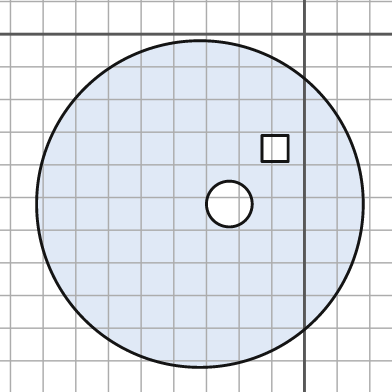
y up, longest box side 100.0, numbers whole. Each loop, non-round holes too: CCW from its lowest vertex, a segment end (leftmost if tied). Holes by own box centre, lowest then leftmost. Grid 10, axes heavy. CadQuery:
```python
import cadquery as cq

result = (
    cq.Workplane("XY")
    .moveTo(-32.0, -52.0)
    .circle(50.0)
    .moveTo(-23.0, -52.0)
    .circle(7.0)
    .moveTo(-13.0, -39.0)
    .lineTo(-5.0, -39.0)
    .lineTo(-5.0, -31.0)
    .lineTo(-13.0, -31.0)
    .close()
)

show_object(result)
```